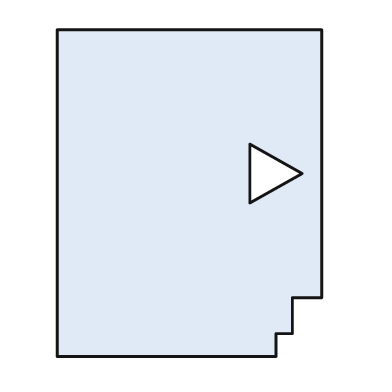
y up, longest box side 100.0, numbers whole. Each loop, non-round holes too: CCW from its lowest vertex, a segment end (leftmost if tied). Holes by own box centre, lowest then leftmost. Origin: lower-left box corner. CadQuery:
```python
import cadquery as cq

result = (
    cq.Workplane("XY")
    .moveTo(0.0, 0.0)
    .lineTo(67.0, 0.0)
    .lineTo(67.0, 7.0)
    .lineTo(72.0, 7.0)
    .lineTo(72.0, 18.0)
    .lineTo(81.0, 18.0)
    .lineTo(81.0, 100.0)
    .lineTo(0.0, 100.0)
    .close()
    .moveTo(59.0, 47.0)
    .lineTo(75.0, 56.0)
    .lineTo(59.0, 65.0)
    .close()
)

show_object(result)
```